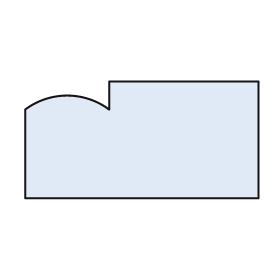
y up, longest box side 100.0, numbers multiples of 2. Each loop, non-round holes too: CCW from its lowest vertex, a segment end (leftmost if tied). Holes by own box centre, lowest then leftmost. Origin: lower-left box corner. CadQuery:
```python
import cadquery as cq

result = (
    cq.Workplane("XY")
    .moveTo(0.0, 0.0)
    .lineTo(100.0, 0.0)
    .lineTo(100.0, 50.0)
    .lineTo(36.0, 50.0)
    .lineTo(36.0, 38.0)
    .threePointArc((18.0, 44.0), (0.0, 38.0))
    .close()
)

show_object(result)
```